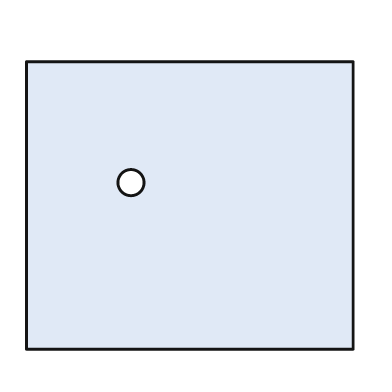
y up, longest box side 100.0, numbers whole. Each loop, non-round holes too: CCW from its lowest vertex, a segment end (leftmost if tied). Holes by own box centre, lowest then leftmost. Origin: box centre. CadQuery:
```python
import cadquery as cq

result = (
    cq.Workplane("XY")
    .moveTo(-50.0, -44.0)
    .lineTo(50.0, -44.0)
    .lineTo(50.0, 44.0)
    .lineTo(-50.0, 44.0)
    .close()
    .moveTo(-18.0, 7.0)
    .circle(4.0)
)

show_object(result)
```